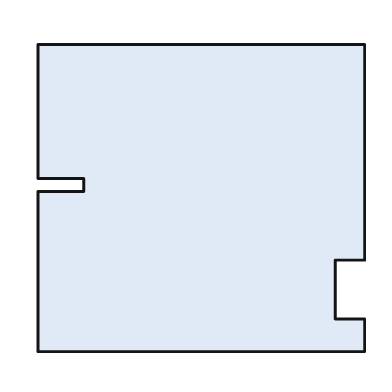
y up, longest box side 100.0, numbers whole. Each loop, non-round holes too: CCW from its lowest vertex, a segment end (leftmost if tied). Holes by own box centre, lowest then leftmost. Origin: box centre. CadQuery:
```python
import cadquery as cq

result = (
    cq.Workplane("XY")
    .moveTo(-50.0, -47.0)
    .lineTo(50.0, -47.0)
    .lineTo(50.0, -37.0)
    .lineTo(41.0, -37.0)
    .lineTo(41.0, -19.0)
    .lineTo(50.0, -19.0)
    .lineTo(50.0, 47.0)
    .lineTo(-50.0, 47.0)
    .lineTo(-50.0, 6.0)
    .lineTo(-36.0, 6.0)
    .lineTo(-36.0, 2.0)
    .lineTo(-50.0, 2.0)
    .close()
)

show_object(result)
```